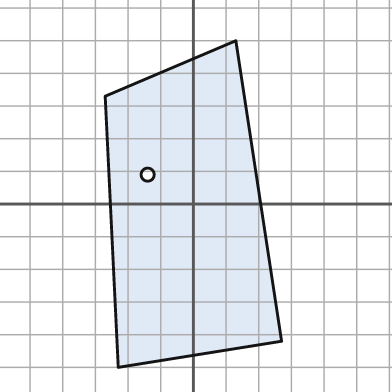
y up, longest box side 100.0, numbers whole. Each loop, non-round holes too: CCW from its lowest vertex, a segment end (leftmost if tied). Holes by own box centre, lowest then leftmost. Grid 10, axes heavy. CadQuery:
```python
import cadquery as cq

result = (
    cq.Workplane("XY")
    .moveTo(-23.0, -50.0)
    .lineTo(27.0, -42.0)
    .lineTo(13.0, 50.0)
    .lineTo(-27.0, 33.0)
    .close()
    .moveTo(-14.0, 9.0)
    .circle(2.0)
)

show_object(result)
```